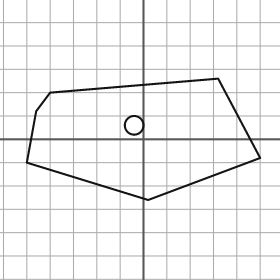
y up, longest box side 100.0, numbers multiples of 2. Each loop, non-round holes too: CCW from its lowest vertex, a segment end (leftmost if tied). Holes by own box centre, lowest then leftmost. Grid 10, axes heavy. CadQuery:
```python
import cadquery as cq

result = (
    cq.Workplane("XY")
    .moveTo(2.0, -26.0)
    .lineTo(50.0, -8.0)
    .lineTo(32.0, 26.0)
    .lineTo(-40.0, 20.0)
    .lineTo(-46.0, 12.0)
    .lineTo(-50.0, -10.0)
    .close()
    .moveTo(-4.0, 6.0)
    .circle(4.0)
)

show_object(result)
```